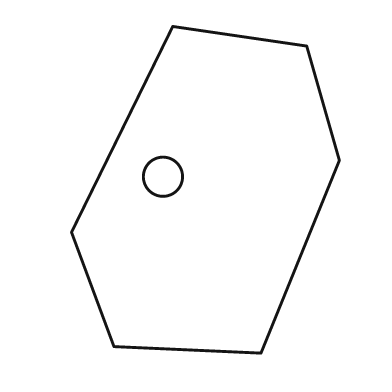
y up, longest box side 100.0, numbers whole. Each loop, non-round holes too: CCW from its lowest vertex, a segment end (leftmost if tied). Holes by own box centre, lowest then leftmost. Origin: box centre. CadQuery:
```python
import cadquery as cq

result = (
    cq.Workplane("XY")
    .moveTo(17.0, -50.0)
    .lineTo(41.0, 9.0)
    .lineTo(31.0, 44.0)
    .lineTo(-10.0, 50.0)
    .lineTo(-41.0, -13.0)
    .lineTo(-28.0, -48.0)
    .close()
    .moveTo(-13.0, 4.0)
    .circle(6.0)
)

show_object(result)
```